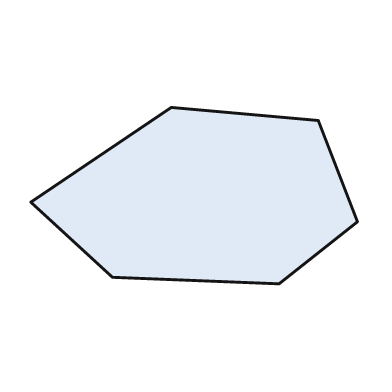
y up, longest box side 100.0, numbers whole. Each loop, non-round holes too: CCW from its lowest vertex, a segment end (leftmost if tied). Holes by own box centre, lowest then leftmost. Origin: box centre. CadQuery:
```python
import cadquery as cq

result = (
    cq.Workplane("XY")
    .moveTo(26.0, -27.0)
    .lineTo(50.0, -8.0)
    .lineTo(38.0, 23.0)
    .lineTo(-7.0, 27.0)
    .lineTo(-50.0, -2.0)
    .lineTo(-25.0, -25.0)
    .close()
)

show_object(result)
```